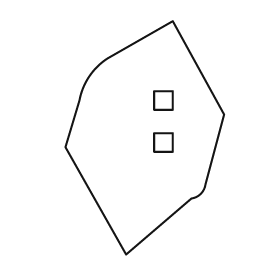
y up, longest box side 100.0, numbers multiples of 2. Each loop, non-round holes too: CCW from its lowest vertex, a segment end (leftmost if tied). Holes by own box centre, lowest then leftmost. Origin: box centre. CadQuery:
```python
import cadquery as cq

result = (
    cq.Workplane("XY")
    .moveTo(-8.0, -50.0)
    .lineTo(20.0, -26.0)
    .threePointArc((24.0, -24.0), (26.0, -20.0))
    .lineTo(34.0, 10.0)
    .lineTo(12.0, 50.0)
    .lineTo(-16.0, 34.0)
    .threePointArc((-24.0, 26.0), (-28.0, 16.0))
    .lineTo(-34.0, -4.0)
    .close()
    .moveTo(4.0, -6.0)
    .lineTo(12.0, -6.0)
    .lineTo(12.0, 2.0)
    .lineTo(4.0, 2.0)
    .close()
    .moveTo(4.0, 12.0)
    .lineTo(12.0, 12.0)
    .lineTo(12.0, 20.0)
    .lineTo(4.0, 20.0)
    .close()
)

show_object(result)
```